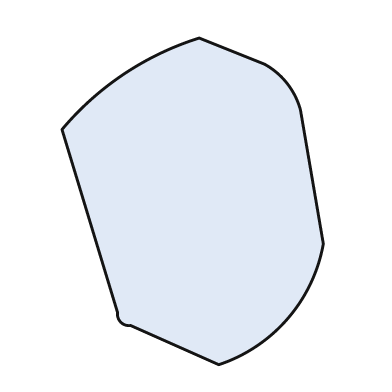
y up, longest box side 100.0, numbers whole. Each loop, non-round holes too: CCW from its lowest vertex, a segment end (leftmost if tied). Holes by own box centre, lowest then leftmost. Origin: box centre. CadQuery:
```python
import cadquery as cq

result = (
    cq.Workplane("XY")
    .moveTo(8.0, -50.0)
    .threePointArc((29.0, -36.0), (40.0, -13.0))
    .lineTo(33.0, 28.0)
    .threePointArc((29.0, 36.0), (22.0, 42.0))
    .lineTo(2.0, 50.0)
    .threePointArc((-21.0, 39.0), (-40.0, 22.0))
    .lineTo(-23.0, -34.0)
    .threePointArc((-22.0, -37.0), (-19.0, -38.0))
    .close()
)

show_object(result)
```